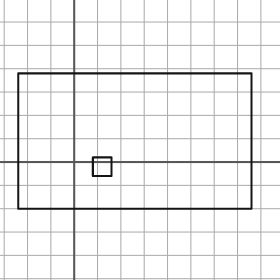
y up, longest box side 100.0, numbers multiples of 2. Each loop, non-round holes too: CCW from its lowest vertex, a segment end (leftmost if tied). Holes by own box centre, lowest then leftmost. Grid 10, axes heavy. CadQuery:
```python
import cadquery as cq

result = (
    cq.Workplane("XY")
    .moveTo(-24.0, -20.0)
    .lineTo(76.0, -20.0)
    .lineTo(76.0, 38.0)
    .lineTo(-24.0, 38.0)
    .close()
    .moveTo(8.0, -6.0)
    .lineTo(16.0, -6.0)
    .lineTo(16.0, 2.0)
    .lineTo(8.0, 2.0)
    .close()
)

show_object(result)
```